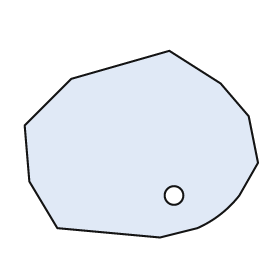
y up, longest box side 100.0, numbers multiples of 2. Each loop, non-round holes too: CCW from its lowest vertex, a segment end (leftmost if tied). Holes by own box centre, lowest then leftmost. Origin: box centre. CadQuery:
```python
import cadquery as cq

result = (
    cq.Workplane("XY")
    .moveTo(8.0, -40.0)
    .lineTo(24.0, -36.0)
    .threePointArc((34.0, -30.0), (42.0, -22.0))
    .lineTo(50.0, -8.0)
    .lineTo(46.0, 12.0)
    .lineTo(34.0, 26.0)
    .lineTo(12.0, 40.0)
    .lineTo(-30.0, 28.0)
    .lineTo(-50.0, 8.0)
    .lineTo(-48.0, -16.0)
    .lineTo(-36.0, -36.0)
    .close()
    .moveTo(14.0, -22.0)
    .circle(4.0)
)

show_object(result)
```